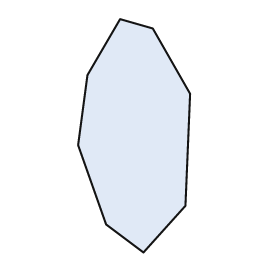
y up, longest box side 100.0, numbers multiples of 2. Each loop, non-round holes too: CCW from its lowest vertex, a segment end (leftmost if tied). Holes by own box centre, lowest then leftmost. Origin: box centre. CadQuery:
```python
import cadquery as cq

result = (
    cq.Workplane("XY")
    .moveTo(4.0, -50.0)
    .lineTo(22.0, -30.0)
    .lineTo(24.0, 18.0)
    .lineTo(8.0, 46.0)
    .lineTo(-6.0, 50.0)
    .lineTo(-20.0, 26.0)
    .lineTo(-24.0, -4.0)
    .lineTo(-12.0, -38.0)
    .close()
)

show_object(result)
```